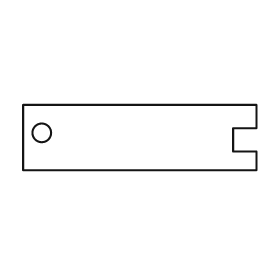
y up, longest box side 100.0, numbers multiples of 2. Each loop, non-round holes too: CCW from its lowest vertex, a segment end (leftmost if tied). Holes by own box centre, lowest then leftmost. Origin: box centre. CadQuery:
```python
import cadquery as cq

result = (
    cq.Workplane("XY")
    .moveTo(-50.0, -14.0)
    .lineTo(50.0, -14.0)
    .lineTo(50.0, -6.0)
    .lineTo(40.0, -6.0)
    .lineTo(40.0, 4.0)
    .lineTo(50.0, 4.0)
    .lineTo(50.0, 14.0)
    .lineTo(-50.0, 14.0)
    .close()
    .moveTo(-42.0, 2.0)
    .circle(4.0)
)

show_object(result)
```